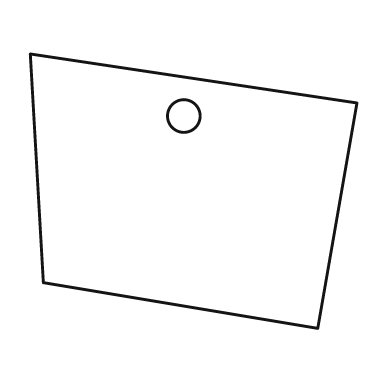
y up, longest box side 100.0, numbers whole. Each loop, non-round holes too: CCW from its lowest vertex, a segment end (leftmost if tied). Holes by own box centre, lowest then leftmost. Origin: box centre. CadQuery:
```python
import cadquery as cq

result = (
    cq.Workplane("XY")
    .moveTo(38.0, -42.0)
    .lineTo(50.0, 27.0)
    .lineTo(-50.0, 42.0)
    .lineTo(-46.0, -28.0)
    .close()
    .moveTo(-3.0, 23.0)
    .circle(5.0)
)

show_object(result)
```